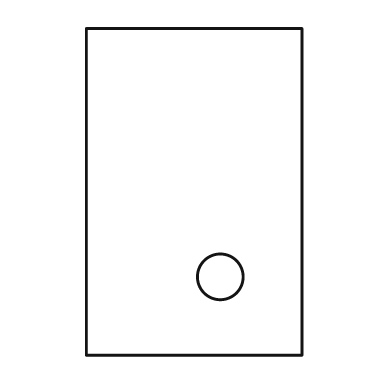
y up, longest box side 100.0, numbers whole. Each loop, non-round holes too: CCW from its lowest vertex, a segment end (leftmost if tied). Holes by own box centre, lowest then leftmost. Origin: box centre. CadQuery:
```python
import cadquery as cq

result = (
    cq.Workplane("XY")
    .moveTo(-33.0, -50.0)
    .lineTo(33.0, -50.0)
    .lineTo(33.0, 50.0)
    .lineTo(-33.0, 50.0)
    .close()
    .moveTo(8.0, -26.0)
    .circle(7.0)
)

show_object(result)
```